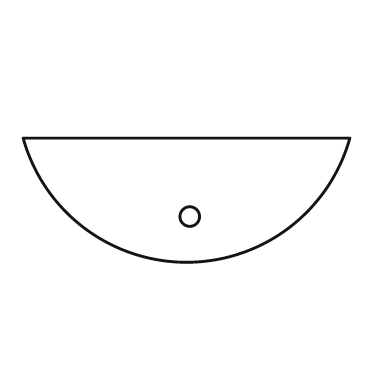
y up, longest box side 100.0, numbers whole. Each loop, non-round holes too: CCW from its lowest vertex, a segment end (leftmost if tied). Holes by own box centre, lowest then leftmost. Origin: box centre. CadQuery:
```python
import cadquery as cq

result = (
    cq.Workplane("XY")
    .moveTo(-50.0, 19.0)
    .threePointArc((0.0, -19.0), (50.0, 19.0))
    .close()
    .moveTo(1.0, -5.0)
    .circle(3.0)
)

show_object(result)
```